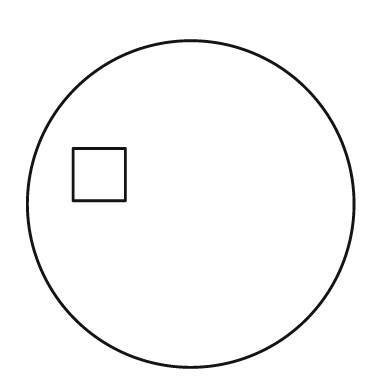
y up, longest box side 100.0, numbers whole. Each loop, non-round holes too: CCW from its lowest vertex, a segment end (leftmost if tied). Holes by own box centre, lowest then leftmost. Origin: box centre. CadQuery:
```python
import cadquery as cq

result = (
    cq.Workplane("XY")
    .moveTo(0.0, 0.0)
    .circle(50.0)
    .moveTo(-36.0, 1.0)
    .lineTo(-20.0, 1.0)
    .lineTo(-20.0, 17.0)
    .lineTo(-36.0, 17.0)
    .close()
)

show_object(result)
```